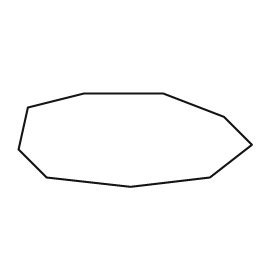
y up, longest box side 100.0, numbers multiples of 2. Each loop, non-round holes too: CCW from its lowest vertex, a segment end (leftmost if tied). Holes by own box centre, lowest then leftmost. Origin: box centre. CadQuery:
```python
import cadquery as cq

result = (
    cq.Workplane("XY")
    .moveTo(-2.0, -20.0)
    .lineTo(32.0, -16.0)
    .lineTo(50.0, -2.0)
    .lineTo(38.0, 10.0)
    .lineTo(12.0, 20.0)
    .lineTo(-22.0, 20.0)
    .lineTo(-46.0, 14.0)
    .lineTo(-50.0, -4.0)
    .lineTo(-38.0, -16.0)
    .close()
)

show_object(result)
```